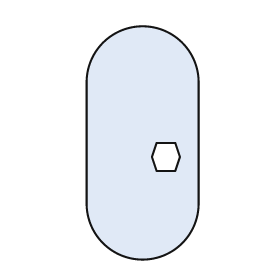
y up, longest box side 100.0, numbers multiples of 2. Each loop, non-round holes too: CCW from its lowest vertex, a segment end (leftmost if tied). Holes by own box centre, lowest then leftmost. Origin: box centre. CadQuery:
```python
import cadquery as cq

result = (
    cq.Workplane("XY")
    .moveTo(-24.0, -26.0)
    .threePointArc((0.0, -50.0), (24.0, -26.0))
    .lineTo(24.0, 26.0)
    .threePointArc((0.0, 50.0), (-24.0, 26.0))
    .close()
    .moveTo(6.0, -12.0)
    .lineTo(14.0, -12.0)
    .lineTo(16.0, -6.0)
    .lineTo(14.0, 0.0)
    .lineTo(6.0, 0.0)
    .lineTo(4.0, -6.0)
    .close()
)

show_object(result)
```